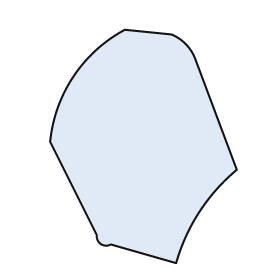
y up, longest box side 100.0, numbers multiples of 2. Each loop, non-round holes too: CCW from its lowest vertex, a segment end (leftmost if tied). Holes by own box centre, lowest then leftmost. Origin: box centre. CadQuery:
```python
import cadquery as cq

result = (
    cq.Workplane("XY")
    .moveTo(14.0, -50.0)
    .threePointArc((24.0, -28.0), (40.0, -10.0))
    .lineTo(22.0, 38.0)
    .threePointArc((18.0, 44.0), (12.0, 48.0))
    .lineTo(-8.0, 50.0)
    .threePointArc((-30.0, 30.0), (-40.0, 2.0))
    .lineTo(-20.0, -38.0)
    .threePointArc((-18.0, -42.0), (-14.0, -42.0))
    .close()
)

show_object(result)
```